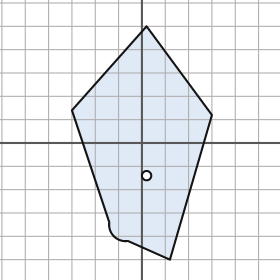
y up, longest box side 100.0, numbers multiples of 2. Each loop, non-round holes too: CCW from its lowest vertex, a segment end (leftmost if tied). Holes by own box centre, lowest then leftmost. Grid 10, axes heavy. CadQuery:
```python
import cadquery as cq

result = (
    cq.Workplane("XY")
    .moveTo(12.0, -50.0)
    .lineTo(30.0, 12.0)
    .lineTo(2.0, 50.0)
    .lineTo(-30.0, 14.0)
    .lineTo(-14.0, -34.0)
    .threePointArc((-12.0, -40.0), (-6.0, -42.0))
    .close()
    .moveTo(2.0, -14.0)
    .circle(2.0)
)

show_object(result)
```